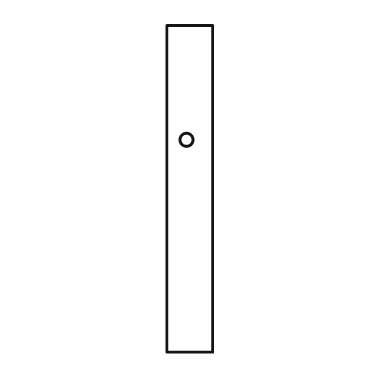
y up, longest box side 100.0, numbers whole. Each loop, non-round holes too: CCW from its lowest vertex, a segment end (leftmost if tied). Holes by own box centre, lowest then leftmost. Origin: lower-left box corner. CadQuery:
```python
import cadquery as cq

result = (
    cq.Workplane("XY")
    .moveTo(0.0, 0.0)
    .lineTo(14.0, 0.0)
    .lineTo(14.0, 100.0)
    .lineTo(0.0, 100.0)
    .close()
    .moveTo(6.0, 65.0)
    .circle(2.0)
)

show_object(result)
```